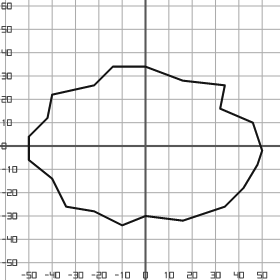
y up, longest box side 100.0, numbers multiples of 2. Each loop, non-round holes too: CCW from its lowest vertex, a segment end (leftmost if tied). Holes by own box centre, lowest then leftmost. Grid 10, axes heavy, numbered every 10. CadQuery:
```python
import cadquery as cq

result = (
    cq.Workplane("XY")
    .moveTo(-10.0, -34.0)
    .lineTo(0.0, -30.0)
    .lineTo(16.0, -32.0)
    .lineTo(34.0, -26.0)
    .lineTo(42.0, -18.0)
    .lineTo(48.0, -8.0)
    .lineTo(50.0, -2.0)
    .lineTo(46.0, 10.0)
    .lineTo(32.0, 16.0)
    .lineTo(34.0, 26.0)
    .lineTo(16.0, 28.0)
    .lineTo(0.0, 34.0)
    .lineTo(-14.0, 34.0)
    .lineTo(-22.0, 26.0)
    .lineTo(-40.0, 22.0)
    .lineTo(-42.0, 12.0)
    .lineTo(-50.0, 4.0)
    .lineTo(-50.0, -6.0)
    .lineTo(-40.0, -14.0)
    .lineTo(-34.0, -26.0)
    .lineTo(-22.0, -28.0)
    .close()
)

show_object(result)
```